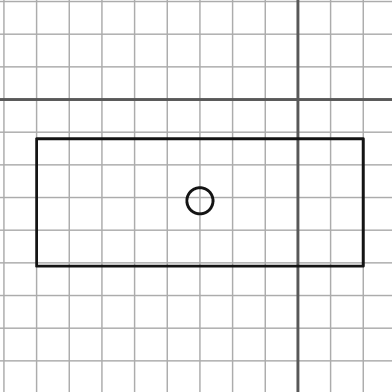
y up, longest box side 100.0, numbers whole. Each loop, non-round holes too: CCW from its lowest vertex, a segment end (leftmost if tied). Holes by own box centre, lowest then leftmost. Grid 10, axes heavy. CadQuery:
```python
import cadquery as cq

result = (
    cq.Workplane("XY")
    .moveTo(-80.0, -51.0)
    .lineTo(20.0, -51.0)
    .lineTo(20.0, -12.0)
    .lineTo(-80.0, -12.0)
    .close()
    .moveTo(-30.0, -31.0)
    .circle(4.0)
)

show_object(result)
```